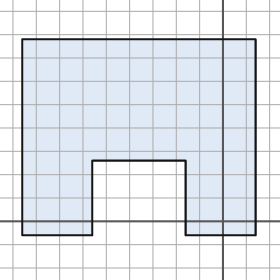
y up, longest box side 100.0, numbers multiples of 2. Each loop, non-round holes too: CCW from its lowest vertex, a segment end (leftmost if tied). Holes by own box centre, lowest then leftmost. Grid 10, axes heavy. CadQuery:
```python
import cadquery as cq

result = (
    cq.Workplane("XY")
    .moveTo(-86.0, -6.0)
    .lineTo(-56.0, -6.0)
    .lineTo(-56.0, 26.0)
    .lineTo(-16.0, 26.0)
    .lineTo(-16.0, -6.0)
    .lineTo(14.0, -6.0)
    .lineTo(14.0, 78.0)
    .lineTo(-86.0, 78.0)
    .close()
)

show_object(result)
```